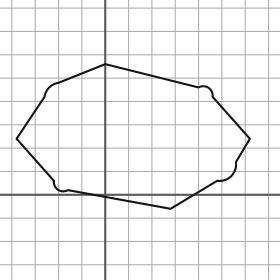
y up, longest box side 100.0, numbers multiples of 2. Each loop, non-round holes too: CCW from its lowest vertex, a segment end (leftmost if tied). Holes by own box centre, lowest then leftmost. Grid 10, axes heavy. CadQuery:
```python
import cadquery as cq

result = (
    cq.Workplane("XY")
    .moveTo(28.0, -6.0)
    .lineTo(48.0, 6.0)
    .threePointArc((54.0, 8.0), (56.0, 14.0))
    .lineTo(62.0, 24.0)
    .lineTo(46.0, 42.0)
    .threePointArc((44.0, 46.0), (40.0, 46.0))
    .lineTo(0.0, 56.0)
    .lineTo(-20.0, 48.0)
    .threePointArc((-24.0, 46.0), (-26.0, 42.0))
    .lineTo(-38.0, 24.0)
    .lineTo(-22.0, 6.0)
    .threePointArc((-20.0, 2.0), (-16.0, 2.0))
    .close()
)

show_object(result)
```